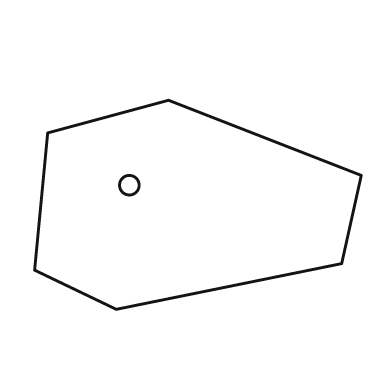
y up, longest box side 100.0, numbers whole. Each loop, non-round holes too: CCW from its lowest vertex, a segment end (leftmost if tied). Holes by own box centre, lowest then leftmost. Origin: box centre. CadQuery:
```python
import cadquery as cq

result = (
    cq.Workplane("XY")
    .moveTo(-25.0, -32.0)
    .lineTo(44.0, -18.0)
    .lineTo(50.0, 9.0)
    .lineTo(-9.0, 32.0)
    .lineTo(-46.0, 22.0)
    .lineTo(-50.0, -20.0)
    .close()
    .moveTo(-21.0, 6.0)
    .circle(3.0)
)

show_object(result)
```